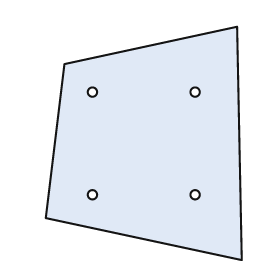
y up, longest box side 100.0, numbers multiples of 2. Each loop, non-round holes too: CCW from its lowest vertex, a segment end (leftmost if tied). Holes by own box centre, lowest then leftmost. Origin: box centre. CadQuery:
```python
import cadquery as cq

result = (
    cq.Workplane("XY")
    .moveTo(42.0, -50.0)
    .lineTo(40.0, 50.0)
    .lineTo(-34.0, 34.0)
    .lineTo(-42.0, -32.0)
    .close()
    .moveTo(-22.0, -22.0)
    .circle(2.0)
    .moveTo(22.0, -22.0)
    .circle(2.0)
    .moveTo(-22.0, 22.0)
    .circle(2.0)
    .moveTo(22.0, 22.0)
    .circle(2.0)
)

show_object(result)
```